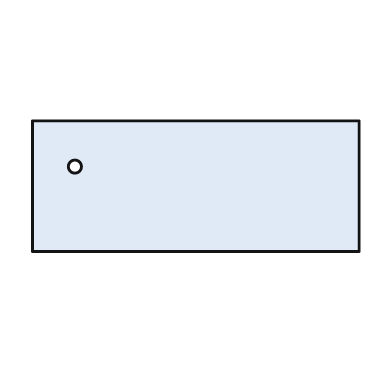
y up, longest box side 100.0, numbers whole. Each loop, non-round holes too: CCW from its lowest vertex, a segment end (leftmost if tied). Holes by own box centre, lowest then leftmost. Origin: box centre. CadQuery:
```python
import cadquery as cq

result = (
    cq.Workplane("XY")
    .moveTo(-50.0, -20.0)
    .lineTo(50.0, -20.0)
    .lineTo(50.0, 20.0)
    .lineTo(-50.0, 20.0)
    .close()
    .moveTo(-37.0, 6.0)
    .circle(2.0)
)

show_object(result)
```